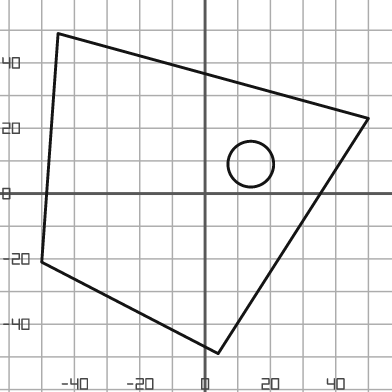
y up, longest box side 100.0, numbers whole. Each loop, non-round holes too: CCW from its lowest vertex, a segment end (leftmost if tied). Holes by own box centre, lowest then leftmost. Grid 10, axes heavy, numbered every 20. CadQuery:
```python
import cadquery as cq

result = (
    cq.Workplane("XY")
    .moveTo(4.0, -49.0)
    .lineTo(50.0, 23.0)
    .lineTo(-45.0, 49.0)
    .lineTo(-50.0, -21.0)
    .close()
    .moveTo(14.0, 9.0)
    .circle(7.0)
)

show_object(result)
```